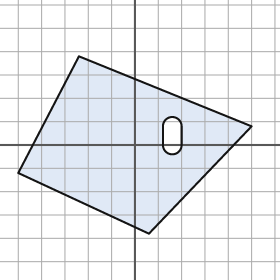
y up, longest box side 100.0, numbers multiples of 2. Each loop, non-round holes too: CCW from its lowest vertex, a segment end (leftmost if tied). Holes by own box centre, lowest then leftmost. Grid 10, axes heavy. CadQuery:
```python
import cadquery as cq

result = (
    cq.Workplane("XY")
    .moveTo(6.0, -38.0)
    .lineTo(50.0, 8.0)
    .lineTo(-24.0, 38.0)
    .lineTo(-50.0, -12.0)
    .close()
    .moveTo(12.0, 0.0)
    .threePointArc((16.0, -4.0), (20.0, 0.0))
    .lineTo(20.0, 8.0)
    .threePointArc((16.0, 12.0), (12.0, 8.0))
    .close()
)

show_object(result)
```